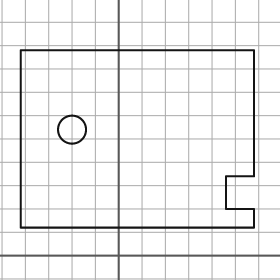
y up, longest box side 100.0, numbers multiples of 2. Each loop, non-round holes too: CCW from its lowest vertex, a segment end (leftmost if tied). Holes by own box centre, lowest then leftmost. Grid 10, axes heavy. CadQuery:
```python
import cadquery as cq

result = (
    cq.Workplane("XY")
    .moveTo(-42.0, 12.0)
    .lineTo(58.0, 12.0)
    .lineTo(58.0, 20.0)
    .lineTo(46.0, 20.0)
    .lineTo(46.0, 34.0)
    .lineTo(58.0, 34.0)
    .lineTo(58.0, 88.0)
    .lineTo(-42.0, 88.0)
    .close()
    .moveTo(-20.0, 54.0)
    .circle(6.0)
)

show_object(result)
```